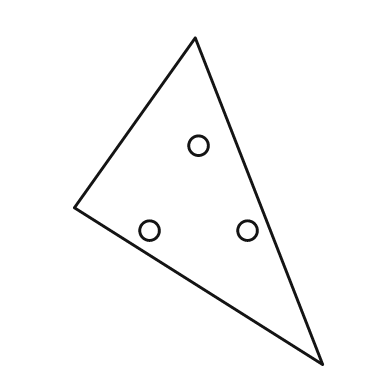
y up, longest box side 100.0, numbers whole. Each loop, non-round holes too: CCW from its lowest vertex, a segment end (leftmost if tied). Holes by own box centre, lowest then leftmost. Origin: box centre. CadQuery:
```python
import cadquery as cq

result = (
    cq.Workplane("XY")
    .moveTo(38.0, -50.0)
    .lineTo(-1.0, 50.0)
    .lineTo(-38.0, -2.0)
    .close()
    .moveTo(-15.0, -9.0)
    .circle(3.0)
    .moveTo(15.0, -9.0)
    .circle(3.0)
    .moveTo(0.0, 17.0)
    .circle(3.0)
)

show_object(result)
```